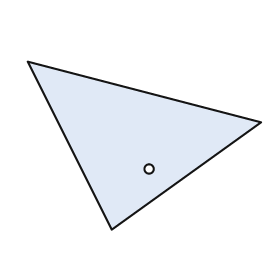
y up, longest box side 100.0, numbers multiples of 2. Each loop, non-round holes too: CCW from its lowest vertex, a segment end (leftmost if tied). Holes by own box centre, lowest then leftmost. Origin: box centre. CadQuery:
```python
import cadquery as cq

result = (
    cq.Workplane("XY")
    .moveTo(-14.0, -36.0)
    .lineTo(50.0, 10.0)
    .lineTo(-50.0, 36.0)
    .close()
    .moveTo(2.0, -10.0)
    .circle(2.0)
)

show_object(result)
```